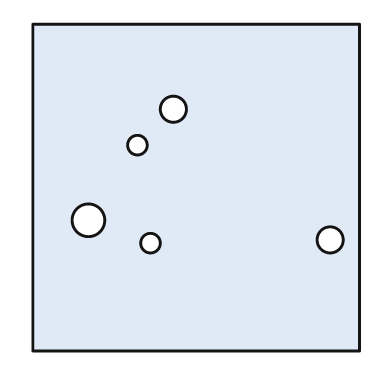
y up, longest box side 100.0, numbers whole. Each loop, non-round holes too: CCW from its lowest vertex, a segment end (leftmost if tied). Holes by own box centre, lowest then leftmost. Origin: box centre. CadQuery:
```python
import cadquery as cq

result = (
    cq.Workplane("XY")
    .moveTo(-50.0, -50.0)
    .lineTo(50.0, -50.0)
    .lineTo(50.0, 50.0)
    .lineTo(-50.0, 50.0)
    .close()
    .moveTo(-14.0, -17.0)
    .circle(3.0)
    .moveTo(41.0, -16.0)
    .circle(4.0)
    .moveTo(-33.0, -10.0)
    .circle(5.0)
    .moveTo(-18.0, 13.0)
    .circle(3.0)
    .moveTo(-7.0, 24.0)
    .circle(4.0)
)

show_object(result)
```